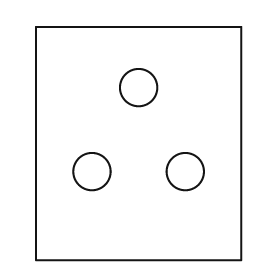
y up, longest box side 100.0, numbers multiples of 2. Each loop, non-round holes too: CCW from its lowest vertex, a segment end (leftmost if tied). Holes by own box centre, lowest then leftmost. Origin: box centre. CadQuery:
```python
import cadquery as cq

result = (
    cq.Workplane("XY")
    .moveTo(-44.0, -50.0)
    .lineTo(44.0, -50.0)
    .lineTo(44.0, 50.0)
    .lineTo(-44.0, 50.0)
    .close()
    .moveTo(-20.0, -12.0)
    .circle(8.0)
    .moveTo(20.0, -12.0)
    .circle(8.0)
    .moveTo(0.0, 24.0)
    .circle(8.0)
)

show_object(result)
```